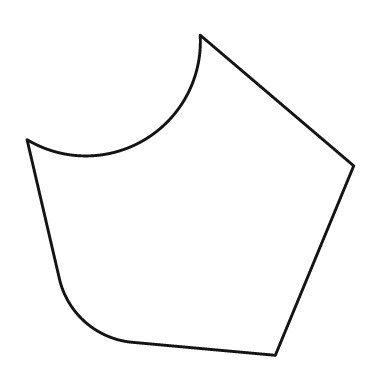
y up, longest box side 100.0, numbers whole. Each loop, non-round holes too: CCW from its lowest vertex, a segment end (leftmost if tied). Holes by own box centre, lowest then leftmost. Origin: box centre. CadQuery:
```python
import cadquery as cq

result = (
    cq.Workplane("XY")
    .moveTo(26.0, -49.0)
    .lineTo(50.0, 9.0)
    .lineTo(3.0, 49.0)
    .threePointArc((-14.0, 17.0), (-50.0, 17.0))
    .lineTo(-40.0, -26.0)
    .threePointArc((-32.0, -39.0), (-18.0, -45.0))
    .close()
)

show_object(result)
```